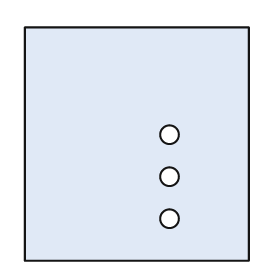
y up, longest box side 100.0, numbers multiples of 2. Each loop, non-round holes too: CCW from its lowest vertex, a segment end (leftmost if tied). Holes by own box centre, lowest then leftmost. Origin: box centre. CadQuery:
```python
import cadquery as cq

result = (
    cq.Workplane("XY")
    .moveTo(-48.0, -50.0)
    .lineTo(48.0, -50.0)
    .lineTo(48.0, 50.0)
    .lineTo(-48.0, 50.0)
    .close()
    .moveTo(14.0, -32.0)
    .circle(4.0)
    .moveTo(14.0, -14.0)
    .circle(4.0)
    .moveTo(14.0, 4.0)
    .circle(4.0)
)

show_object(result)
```